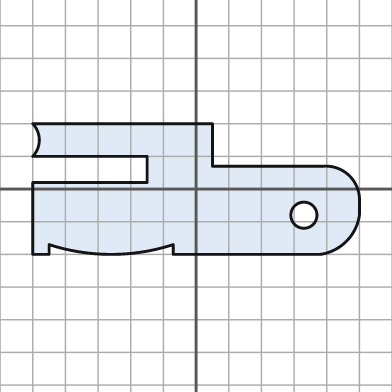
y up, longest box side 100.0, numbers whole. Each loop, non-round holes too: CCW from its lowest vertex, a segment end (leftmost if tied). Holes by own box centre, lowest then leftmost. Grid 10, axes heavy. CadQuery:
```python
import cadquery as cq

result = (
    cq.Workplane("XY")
    .moveTo(-50.0, -20.0)
    .lineTo(-45.0, -20.0)
    .lineTo(-45.0, -17.0)
    .threePointArc((-26.0, -20.0), (-7.0, -17.0))
    .lineTo(-7.0, -20.0)
    .lineTo(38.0, -20.0)
    .threePointArc((46.0, -16.0), (50.0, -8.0))
    .lineTo(50.0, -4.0)
    .threePointArc((47.0, 4.0), (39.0, 7.0))
    .lineTo(5.0, 7.0)
    .lineTo(5.0, 20.0)
    .lineTo(-50.0, 20.0)
    .threePointArc((-48.0, 15.0), (-50.0, 10.0))
    .lineTo(-15.0, 10.0)
    .lineTo(-15.0, 2.0)
    .lineTo(-50.0, 2.0)
    .close()
    .moveTo(33.0, -8.0)
    .circle(4.0)
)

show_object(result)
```